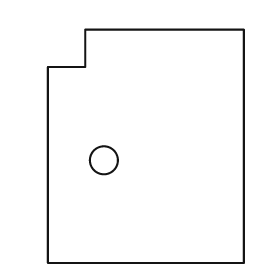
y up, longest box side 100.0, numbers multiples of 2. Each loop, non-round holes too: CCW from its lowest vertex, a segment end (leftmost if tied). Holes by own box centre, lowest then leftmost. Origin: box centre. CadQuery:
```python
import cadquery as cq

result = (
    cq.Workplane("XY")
    .moveTo(-42.0, -50.0)
    .lineTo(42.0, -50.0)
    .lineTo(42.0, 50.0)
    .lineTo(-26.0, 50.0)
    .lineTo(-26.0, 34.0)
    .lineTo(-42.0, 34.0)
    .close()
    .moveTo(-18.0, -6.0)
    .circle(6.0)
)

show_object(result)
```